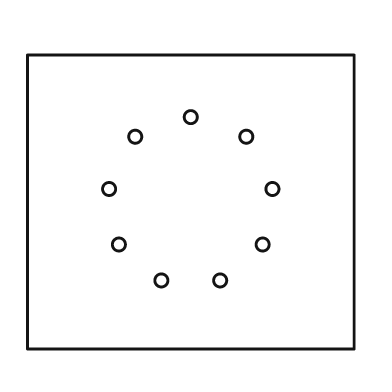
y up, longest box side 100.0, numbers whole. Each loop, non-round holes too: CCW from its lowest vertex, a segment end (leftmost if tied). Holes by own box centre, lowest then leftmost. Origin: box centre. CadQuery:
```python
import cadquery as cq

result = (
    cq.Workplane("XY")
    .moveTo(-50.0, -45.0)
    .lineTo(50.0, -45.0)
    .lineTo(50.0, 45.0)
    .lineTo(-50.0, 45.0)
    .close()
    .moveTo(-9.0, -24.0)
    .circle(2.0)
    .moveTo(9.0, -24.0)
    .circle(2.0)
    .moveTo(-22.0, -13.0)
    .circle(2.0)
    .moveTo(22.0, -13.0)
    .circle(2.0)
    .moveTo(-25.0, 4.0)
    .circle(2.0)
    .moveTo(25.0, 4.0)
    .circle(2.0)
    .moveTo(-17.0, 20.0)
    .circle(2.0)
    .moveTo(17.0, 20.0)
    .circle(2.0)
    .moveTo(0.0, 26.0)
    .circle(2.0)
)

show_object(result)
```